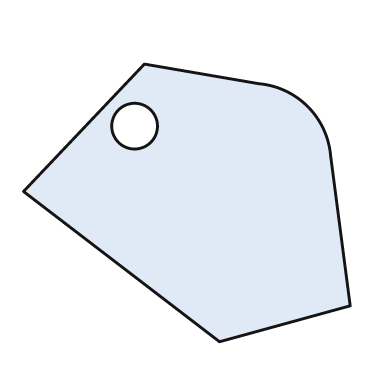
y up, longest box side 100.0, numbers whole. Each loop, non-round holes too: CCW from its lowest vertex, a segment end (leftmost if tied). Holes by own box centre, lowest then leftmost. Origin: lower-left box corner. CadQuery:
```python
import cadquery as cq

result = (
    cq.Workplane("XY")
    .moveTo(60.0, 0.0)
    .lineTo(100.0, 11.0)
    .lineTo(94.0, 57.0)
    .threePointArc((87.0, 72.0), (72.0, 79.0))
    .lineTo(37.0, 85.0)
    .lineTo(0.0, 46.0)
    .close()
    .moveTo(34.0, 66.0)
    .circle(7.0)
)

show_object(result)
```